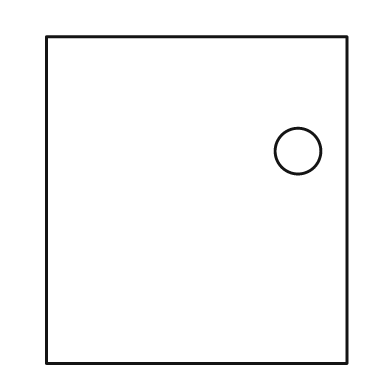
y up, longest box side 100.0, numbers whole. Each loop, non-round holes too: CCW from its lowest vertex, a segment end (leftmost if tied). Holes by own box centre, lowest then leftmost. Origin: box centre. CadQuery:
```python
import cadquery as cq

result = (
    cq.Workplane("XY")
    .moveTo(-46.0, -50.0)
    .lineTo(46.0, -50.0)
    .lineTo(46.0, 50.0)
    .lineTo(-46.0, 50.0)
    .close()
    .moveTo(31.0, 15.0)
    .circle(7.0)
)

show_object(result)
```